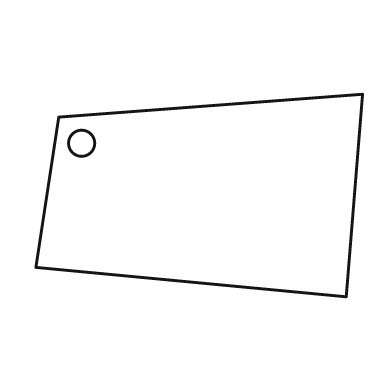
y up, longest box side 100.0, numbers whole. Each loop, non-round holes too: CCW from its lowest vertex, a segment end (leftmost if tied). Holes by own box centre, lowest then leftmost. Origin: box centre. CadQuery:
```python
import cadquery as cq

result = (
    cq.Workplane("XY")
    .moveTo(45.0, -31.0)
    .lineTo(50.0, 31.0)
    .lineTo(-43.0, 24.0)
    .lineTo(-50.0, -22.0)
    .close()
    .moveTo(-36.0, 16.0)
    .circle(4.0)
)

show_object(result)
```